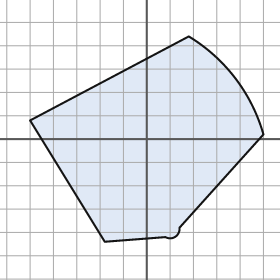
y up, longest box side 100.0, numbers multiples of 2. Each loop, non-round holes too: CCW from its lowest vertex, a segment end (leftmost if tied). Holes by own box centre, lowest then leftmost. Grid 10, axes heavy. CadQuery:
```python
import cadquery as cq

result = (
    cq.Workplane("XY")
    .moveTo(-18.0, -44.0)
    .lineTo(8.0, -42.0)
    .threePointArc((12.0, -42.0), (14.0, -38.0))
    .lineTo(50.0, 2.0)
    .threePointArc((38.0, 26.0), (18.0, 44.0))
    .lineTo(-50.0, 8.0)
    .close()
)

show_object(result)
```